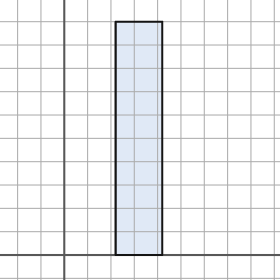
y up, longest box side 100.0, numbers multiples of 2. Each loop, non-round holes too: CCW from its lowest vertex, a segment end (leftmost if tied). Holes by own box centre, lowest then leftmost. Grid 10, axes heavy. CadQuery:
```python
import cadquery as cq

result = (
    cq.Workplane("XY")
    .moveTo(22.0, 0.0)
    .lineTo(42.0, 0.0)
    .lineTo(42.0, 100.0)
    .lineTo(22.0, 100.0)
    .close()
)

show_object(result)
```